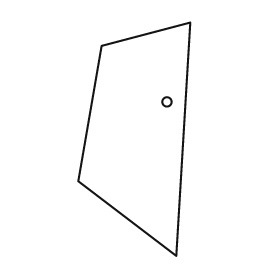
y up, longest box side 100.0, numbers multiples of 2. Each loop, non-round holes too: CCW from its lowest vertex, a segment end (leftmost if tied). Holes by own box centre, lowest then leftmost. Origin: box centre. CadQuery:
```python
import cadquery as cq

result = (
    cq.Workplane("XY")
    .moveTo(18.0, -50.0)
    .lineTo(24.0, 50.0)
    .lineTo(-14.0, 40.0)
    .lineTo(-24.0, -18.0)
    .close()
    .moveTo(14.0, 16.0)
    .circle(2.0)
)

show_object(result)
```